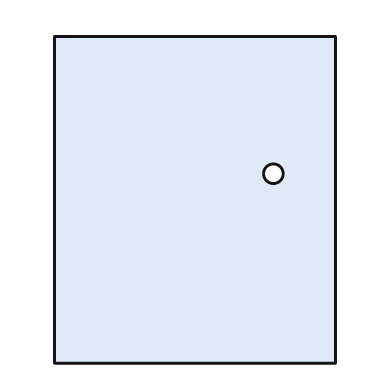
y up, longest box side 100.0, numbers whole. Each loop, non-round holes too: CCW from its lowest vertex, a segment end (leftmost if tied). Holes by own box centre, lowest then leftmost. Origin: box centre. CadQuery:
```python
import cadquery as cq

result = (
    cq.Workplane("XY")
    .moveTo(-43.0, -50.0)
    .lineTo(43.0, -50.0)
    .lineTo(43.0, 50.0)
    .lineTo(-43.0, 50.0)
    .close()
    .moveTo(24.0, 8.0)
    .circle(3.0)
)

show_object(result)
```